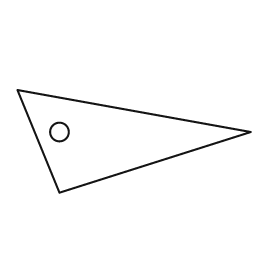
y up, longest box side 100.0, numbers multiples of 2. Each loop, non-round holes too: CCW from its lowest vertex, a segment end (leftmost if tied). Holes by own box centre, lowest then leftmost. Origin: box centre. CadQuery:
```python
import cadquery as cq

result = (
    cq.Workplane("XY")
    .moveTo(-32.0, -22.0)
    .lineTo(50.0, 4.0)
    .lineTo(-50.0, 22.0)
    .close()
    .moveTo(-32.0, 4.0)
    .circle(4.0)
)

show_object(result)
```